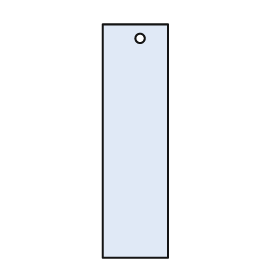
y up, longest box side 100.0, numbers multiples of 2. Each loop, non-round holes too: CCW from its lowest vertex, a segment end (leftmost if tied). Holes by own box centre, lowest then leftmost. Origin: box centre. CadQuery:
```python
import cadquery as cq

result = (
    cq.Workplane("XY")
    .moveTo(-14.0, -50.0)
    .lineTo(14.0, -50.0)
    .lineTo(14.0, 50.0)
    .lineTo(-14.0, 50.0)
    .close()
    .moveTo(2.0, 44.0)
    .circle(2.0)
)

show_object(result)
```